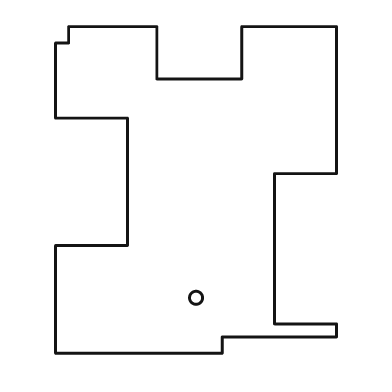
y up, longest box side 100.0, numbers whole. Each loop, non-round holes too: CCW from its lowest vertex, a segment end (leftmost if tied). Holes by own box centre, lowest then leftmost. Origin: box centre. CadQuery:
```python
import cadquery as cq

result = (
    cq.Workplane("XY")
    .moveTo(-43.0, -50.0)
    .lineTo(8.0, -50.0)
    .lineTo(8.0, -45.0)
    .lineTo(43.0, -45.0)
    .lineTo(43.0, -41.0)
    .lineTo(24.0, -41.0)
    .lineTo(24.0, 5.0)
    .lineTo(43.0, 5.0)
    .lineTo(43.0, 50.0)
    .lineTo(14.0, 50.0)
    .lineTo(14.0, 34.0)
    .lineTo(-12.0, 34.0)
    .lineTo(-12.0, 50.0)
    .lineTo(-39.0, 50.0)
    .lineTo(-39.0, 45.0)
    .lineTo(-43.0, 45.0)
    .lineTo(-43.0, 22.0)
    .lineTo(-21.0, 22.0)
    .lineTo(-21.0, -17.0)
    .lineTo(-43.0, -17.0)
    .close()
    .moveTo(0.0, -33.0)
    .circle(2.0)
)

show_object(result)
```